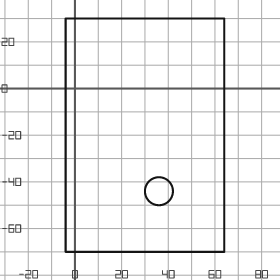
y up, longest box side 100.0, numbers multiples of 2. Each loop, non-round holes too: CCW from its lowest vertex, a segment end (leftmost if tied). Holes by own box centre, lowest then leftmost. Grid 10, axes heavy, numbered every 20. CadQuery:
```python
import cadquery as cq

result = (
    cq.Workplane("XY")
    .moveTo(-4.0, -70.0)
    .lineTo(64.0, -70.0)
    .lineTo(64.0, 30.0)
    .lineTo(-4.0, 30.0)
    .close()
    .moveTo(36.0, -44.0)
    .circle(6.0)
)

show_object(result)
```